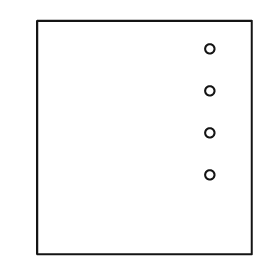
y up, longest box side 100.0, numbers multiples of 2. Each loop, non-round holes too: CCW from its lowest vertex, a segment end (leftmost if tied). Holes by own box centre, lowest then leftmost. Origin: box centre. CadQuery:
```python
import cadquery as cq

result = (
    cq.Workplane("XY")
    .moveTo(-46.0, -50.0)
    .lineTo(46.0, -50.0)
    .lineTo(46.0, 50.0)
    .lineTo(-46.0, 50.0)
    .close()
    .moveTo(28.0, -16.0)
    .circle(2.0)
    .moveTo(28.0, 2.0)
    .circle(2.0)
    .moveTo(28.0, 20.0)
    .circle(2.0)
    .moveTo(28.0, 38.0)
    .circle(2.0)
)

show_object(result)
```